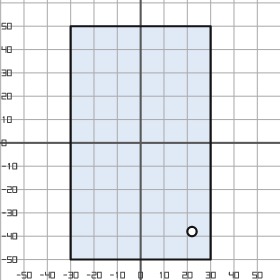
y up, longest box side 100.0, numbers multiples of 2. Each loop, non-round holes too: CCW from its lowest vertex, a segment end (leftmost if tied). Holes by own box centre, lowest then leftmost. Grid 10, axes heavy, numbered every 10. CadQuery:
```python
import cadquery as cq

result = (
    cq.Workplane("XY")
    .moveTo(-30.0, -50.0)
    .lineTo(30.0, -50.0)
    .lineTo(30.0, 50.0)
    .lineTo(-30.0, 50.0)
    .close()
    .moveTo(22.0, -38.0)
    .circle(2.0)
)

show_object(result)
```